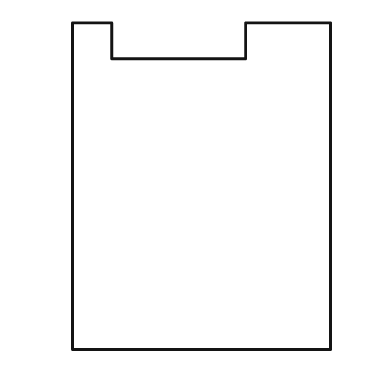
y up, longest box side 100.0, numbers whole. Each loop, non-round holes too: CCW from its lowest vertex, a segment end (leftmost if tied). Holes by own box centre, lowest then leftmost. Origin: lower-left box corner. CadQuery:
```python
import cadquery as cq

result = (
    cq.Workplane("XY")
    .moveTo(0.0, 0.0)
    .lineTo(79.0, 0.0)
    .lineTo(79.0, 100.0)
    .lineTo(53.0, 100.0)
    .lineTo(53.0, 89.0)
    .lineTo(12.0, 89.0)
    .lineTo(12.0, 100.0)
    .lineTo(0.0, 100.0)
    .close()
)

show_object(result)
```